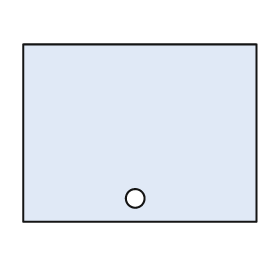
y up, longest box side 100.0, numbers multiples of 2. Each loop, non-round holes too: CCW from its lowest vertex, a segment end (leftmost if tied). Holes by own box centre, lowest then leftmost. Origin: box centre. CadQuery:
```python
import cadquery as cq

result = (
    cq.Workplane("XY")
    .moveTo(-50.0, -38.0)
    .lineTo(50.0, -38.0)
    .lineTo(50.0, 38.0)
    .lineTo(-50.0, 38.0)
    .close()
    .moveTo(-2.0, -28.0)
    .circle(4.0)
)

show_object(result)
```